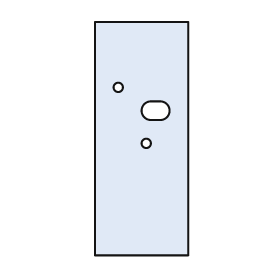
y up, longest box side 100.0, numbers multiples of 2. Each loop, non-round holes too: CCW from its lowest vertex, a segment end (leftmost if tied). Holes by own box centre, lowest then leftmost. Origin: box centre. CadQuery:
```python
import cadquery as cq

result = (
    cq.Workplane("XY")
    .moveTo(-20.0, -50.0)
    .lineTo(20.0, -50.0)
    .lineTo(20.0, 50.0)
    .lineTo(-20.0, 50.0)
    .close()
    .moveTo(2.0, -2.0)
    .circle(2.0)
    .moveTo(4.0, 8.0)
    .lineTo(8.0, 8.0)
    .threePointArc((12.0, 12.0), (8.0, 16.0))
    .lineTo(4.0, 16.0)
    .threePointArc((0.0, 12.0), (4.0, 8.0))
    .close()
    .moveTo(-10.0, 22.0)
    .circle(2.0)
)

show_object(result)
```